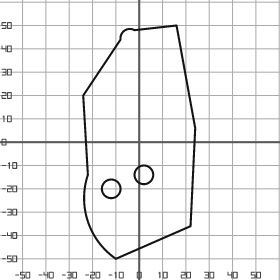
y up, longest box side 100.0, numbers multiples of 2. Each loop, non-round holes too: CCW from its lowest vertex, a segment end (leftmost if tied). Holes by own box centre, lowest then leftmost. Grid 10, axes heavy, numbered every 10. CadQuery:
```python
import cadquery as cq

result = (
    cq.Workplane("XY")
    .moveTo(-10.0, -50.0)
    .lineTo(22.0, -36.0)
    .lineTo(24.0, 6.0)
    .lineTo(16.0, 50.0)
    .lineTo(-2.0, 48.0)
    .threePointArc((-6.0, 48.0), (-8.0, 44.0))
    .lineTo(-24.0, 20.0)
    .lineTo(-22.0, -14.0)
    .threePointArc((-22.0, -34.0), (-10.0, -50.0))
    .close()
    .moveTo(-12.0, -20.0)
    .circle(4.0)
    .moveTo(2.0, -14.0)
    .circle(4.0)
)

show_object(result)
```